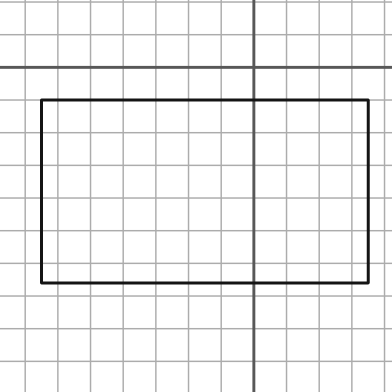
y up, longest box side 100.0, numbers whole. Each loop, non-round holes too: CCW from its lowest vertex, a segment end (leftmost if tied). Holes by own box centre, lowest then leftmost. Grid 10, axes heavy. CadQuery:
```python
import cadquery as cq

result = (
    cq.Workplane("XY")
    .moveTo(-65.0, -66.0)
    .lineTo(35.0, -66.0)
    .lineTo(35.0, -10.0)
    .lineTo(-65.0, -10.0)
    .close()
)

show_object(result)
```